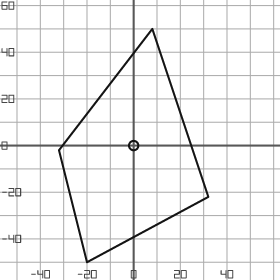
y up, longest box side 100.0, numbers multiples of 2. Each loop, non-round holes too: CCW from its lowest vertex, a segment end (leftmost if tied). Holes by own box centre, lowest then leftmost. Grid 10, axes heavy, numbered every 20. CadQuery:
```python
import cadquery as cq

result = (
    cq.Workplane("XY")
    .moveTo(-20.0, -50.0)
    .lineTo(32.0, -22.0)
    .lineTo(8.0, 50.0)
    .lineTo(-32.0, -2.0)
    .close()
    .moveTo(0.0, 0.0)
    .circle(2.0)
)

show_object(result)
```